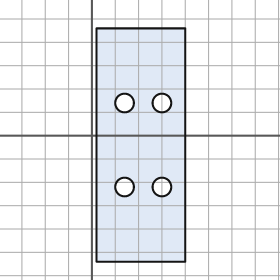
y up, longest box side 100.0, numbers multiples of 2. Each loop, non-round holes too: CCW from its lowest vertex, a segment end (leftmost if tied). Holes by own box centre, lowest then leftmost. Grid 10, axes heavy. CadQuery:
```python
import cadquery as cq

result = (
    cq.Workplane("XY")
    .moveTo(2.0, -54.0)
    .lineTo(40.0, -54.0)
    .lineTo(40.0, 46.0)
    .lineTo(2.0, 46.0)
    .close()
    .moveTo(14.0, -22.0)
    .circle(4.0)
    .moveTo(30.0, -22.0)
    .circle(4.0)
    .moveTo(14.0, 14.0)
    .circle(4.0)
    .moveTo(30.0, 14.0)
    .circle(4.0)
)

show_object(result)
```